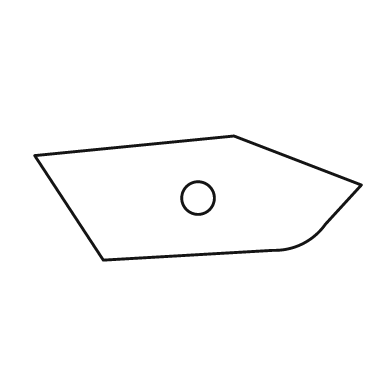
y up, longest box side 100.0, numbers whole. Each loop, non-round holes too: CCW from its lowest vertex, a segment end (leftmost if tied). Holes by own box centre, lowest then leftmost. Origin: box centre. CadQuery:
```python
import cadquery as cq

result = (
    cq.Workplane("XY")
    .moveTo(-29.0, -19.0)
    .lineTo(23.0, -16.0)
    .threePointArc((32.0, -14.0), (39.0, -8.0))
    .lineTo(50.0, 4.0)
    .lineTo(11.0, 19.0)
    .lineTo(-50.0, 13.0)
    .close()
    .moveTo(0.0, 0.0)
    .circle(5.0)
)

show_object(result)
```